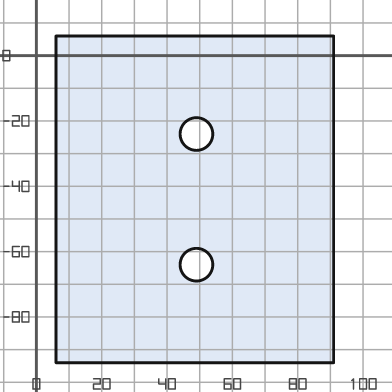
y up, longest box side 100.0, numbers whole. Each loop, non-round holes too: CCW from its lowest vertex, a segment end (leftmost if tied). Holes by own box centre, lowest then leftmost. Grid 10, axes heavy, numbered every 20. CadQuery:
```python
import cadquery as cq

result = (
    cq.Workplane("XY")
    .moveTo(6.0, -94.0)
    .lineTo(91.0, -94.0)
    .lineTo(91.0, 6.0)
    .lineTo(6.0, 6.0)
    .close()
    .moveTo(49.0, -64.0)
    .circle(5.0)
    .moveTo(49.0, -24.0)
    .circle(5.0)
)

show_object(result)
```